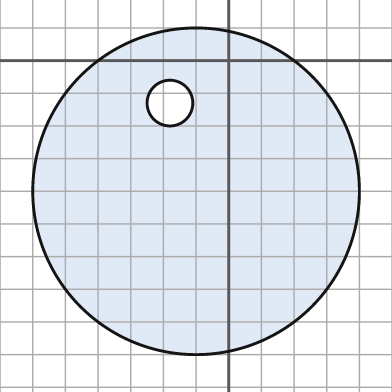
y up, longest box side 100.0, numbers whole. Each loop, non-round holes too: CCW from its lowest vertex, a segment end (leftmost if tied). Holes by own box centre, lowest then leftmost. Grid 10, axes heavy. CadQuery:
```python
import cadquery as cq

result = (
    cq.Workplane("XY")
    .moveTo(-10.0, -40.0)
    .circle(50.0)
    .moveTo(-18.0, -13.0)
    .circle(7.0)
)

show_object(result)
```